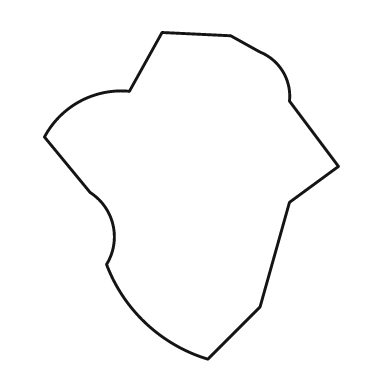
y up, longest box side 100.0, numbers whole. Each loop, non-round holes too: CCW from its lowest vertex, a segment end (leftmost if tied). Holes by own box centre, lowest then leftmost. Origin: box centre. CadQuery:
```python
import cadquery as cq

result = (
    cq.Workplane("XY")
    .moveTo(5.0, -50.0)
    .lineTo(21.0, -34.0)
    .lineTo(30.0, -2.0)
    .lineTo(45.0, 9.0)
    .lineTo(30.0, 29.0)
    .threePointArc((28.0, 38.0), (21.0, 44.0))
    .lineTo(12.0, 49.0)
    .lineTo(-9.0, 50.0)
    .lineTo(-19.0, 32.0)
    .threePointArc((-34.0, 29.0), (-45.0, 18.0))
    .lineTo(-31.0, 1.0)
    .threePointArc((-24.0, -9.0), (-26.0, -21.0))
    .threePointArc((-14.0, -39.0), (5.0, -50.0))
    .close()
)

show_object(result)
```